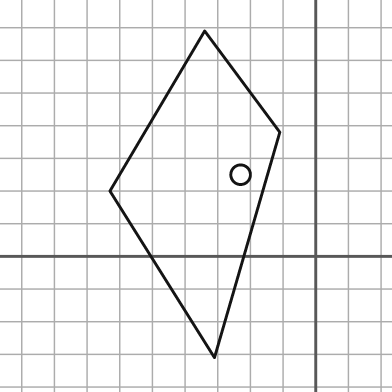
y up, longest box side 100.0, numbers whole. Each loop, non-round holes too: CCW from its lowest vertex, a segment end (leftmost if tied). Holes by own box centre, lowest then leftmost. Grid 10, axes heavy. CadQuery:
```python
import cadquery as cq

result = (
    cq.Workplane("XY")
    .moveTo(-31.0, -31.0)
    .lineTo(-11.0, 38.0)
    .lineTo(-34.0, 69.0)
    .lineTo(-63.0, 20.0)
    .close()
    .moveTo(-23.0, 25.0)
    .circle(3.0)
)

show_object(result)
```